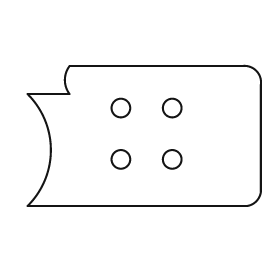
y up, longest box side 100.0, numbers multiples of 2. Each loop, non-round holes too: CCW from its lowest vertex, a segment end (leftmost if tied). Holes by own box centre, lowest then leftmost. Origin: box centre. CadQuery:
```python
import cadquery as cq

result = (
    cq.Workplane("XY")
    .moveTo(-50.0, -30.0)
    .lineTo(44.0, -30.0)
    .threePointArc((48.0, -28.0), (50.0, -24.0))
    .lineTo(50.0, 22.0)
    .threePointArc((48.0, 28.0), (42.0, 30.0))
    .lineTo(-32.0, 30.0)
    .threePointArc((-34.0, 24.0), (-32.0, 18.0))
    .lineTo(-50.0, 18.0)
    .threePointArc((-40.0, -6.0), (-50.0, -30.0))
    .close()
    .moveTo(-10.0, -10.0)
    .circle(4.0)
    .moveTo(12.0, -10.0)
    .circle(4.0)
    .moveTo(-10.0, 12.0)
    .circle(4.0)
    .moveTo(12.0, 12.0)
    .circle(4.0)
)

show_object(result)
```